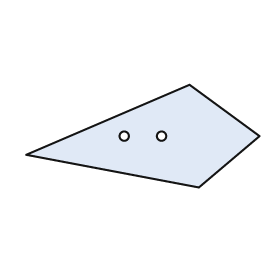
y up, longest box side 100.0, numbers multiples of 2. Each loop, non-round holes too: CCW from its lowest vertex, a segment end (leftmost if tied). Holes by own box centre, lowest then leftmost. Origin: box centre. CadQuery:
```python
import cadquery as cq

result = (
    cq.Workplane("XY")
    .moveTo(24.0, -22.0)
    .lineTo(50.0, 0.0)
    .lineTo(20.0, 22.0)
    .lineTo(-50.0, -8.0)
    .close()
    .moveTo(-8.0, 0.0)
    .circle(2.0)
    .moveTo(8.0, 0.0)
    .circle(2.0)
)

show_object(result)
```